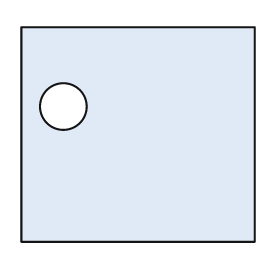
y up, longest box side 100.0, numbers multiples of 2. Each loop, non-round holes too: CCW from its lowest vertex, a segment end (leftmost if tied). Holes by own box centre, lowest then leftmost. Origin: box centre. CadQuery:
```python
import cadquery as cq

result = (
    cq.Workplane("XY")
    .moveTo(-50.0, -46.0)
    .lineTo(50.0, -46.0)
    .lineTo(50.0, 46.0)
    .lineTo(-50.0, 46.0)
    .close()
    .moveTo(-32.0, 12.0)
    .circle(10.0)
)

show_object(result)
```